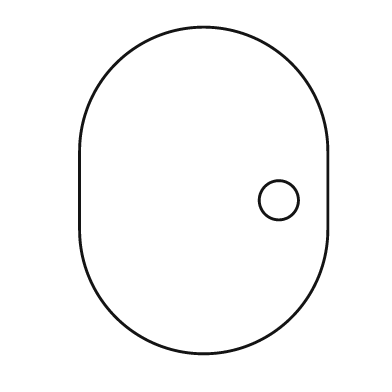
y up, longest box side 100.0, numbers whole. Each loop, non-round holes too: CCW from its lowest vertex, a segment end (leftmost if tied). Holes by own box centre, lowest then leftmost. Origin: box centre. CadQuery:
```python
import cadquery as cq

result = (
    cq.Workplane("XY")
    .moveTo(-38.0, -12.0)
    .threePointArc((0.0, -50.0), (38.0, -12.0))
    .lineTo(38.0, 12.0)
    .threePointArc((0.0, 50.0), (-38.0, 12.0))
    .close()
    .moveTo(23.0, -3.0)
    .circle(6.0)
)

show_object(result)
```